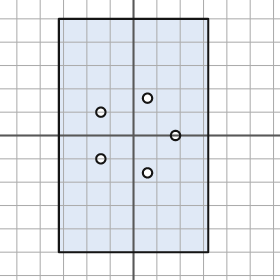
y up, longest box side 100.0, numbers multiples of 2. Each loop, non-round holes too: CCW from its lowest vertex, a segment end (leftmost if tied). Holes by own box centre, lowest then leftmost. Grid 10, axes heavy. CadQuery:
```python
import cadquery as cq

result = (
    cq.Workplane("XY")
    .moveTo(-32.0, -50.0)
    .lineTo(32.0, -50.0)
    .lineTo(32.0, 50.0)
    .lineTo(-32.0, 50.0)
    .close()
    .moveTo(6.0, -16.0)
    .circle(2.0)
    .moveTo(-14.0, -10.0)
    .circle(2.0)
    .moveTo(18.0, 0.0)
    .circle(2.0)
    .moveTo(-14.0, 10.0)
    .circle(2.0)
    .moveTo(6.0, 16.0)
    .circle(2.0)
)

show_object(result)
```